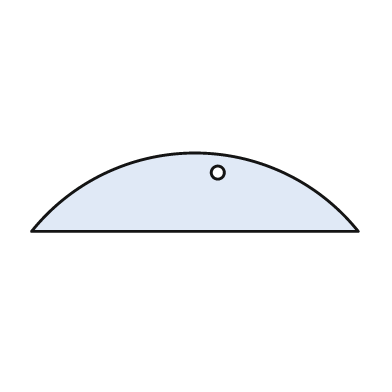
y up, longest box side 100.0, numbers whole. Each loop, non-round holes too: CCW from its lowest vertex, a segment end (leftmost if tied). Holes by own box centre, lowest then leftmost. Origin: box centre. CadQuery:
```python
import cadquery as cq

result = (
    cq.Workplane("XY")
    .moveTo(-50.0, -12.0)
    .lineTo(50.0, -12.0)
    .threePointArc((0.0, 12.0), (-50.0, -12.0))
    .close()
    .moveTo(7.0, 6.0)
    .circle(2.0)
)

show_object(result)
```